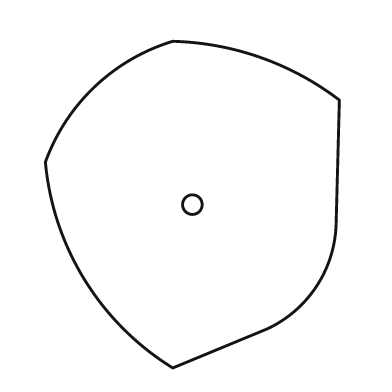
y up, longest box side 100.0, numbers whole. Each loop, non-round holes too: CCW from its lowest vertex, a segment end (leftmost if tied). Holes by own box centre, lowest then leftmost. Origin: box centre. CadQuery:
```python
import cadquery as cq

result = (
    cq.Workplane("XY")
    .moveTo(-6.0, -50.0)
    .lineTo(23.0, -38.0)
    .threePointArc((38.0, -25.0), (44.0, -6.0))
    .lineTo(45.0, 32.0)
    .threePointArc((21.0, 45.0), (-6.0, 50.0))
    .threePointArc((-30.0, 36.0), (-45.0, 13.0))
    .threePointArc((-33.0, -23.0), (-6.0, -50.0))
    .close()
    .moveTo(0.0, 0.0)
    .circle(3.0)
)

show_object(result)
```